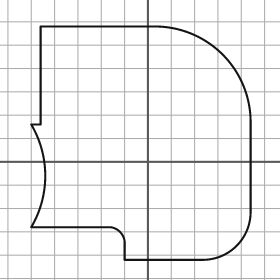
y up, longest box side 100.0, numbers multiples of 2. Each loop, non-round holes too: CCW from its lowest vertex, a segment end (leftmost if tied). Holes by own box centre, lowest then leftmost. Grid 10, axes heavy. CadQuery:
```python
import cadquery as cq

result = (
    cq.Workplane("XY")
    .moveTo(-10.0, -42.0)
    .lineTo(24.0, -42.0)
    .threePointArc((38.0, -36.0), (44.0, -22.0))
    .lineTo(44.0, 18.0)
    .threePointArc((32.0, 46.0), (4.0, 58.0))
    .lineTo(-46.0, 58.0)
    .lineTo(-46.0, 16.0)
    .lineTo(-50.0, 16.0)
    .threePointArc((-44.0, -6.0), (-50.0, -28.0))
    .lineTo(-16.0, -28.0)
    .threePointArc((-12.0, -30.0), (-10.0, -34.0))
    .close()
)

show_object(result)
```